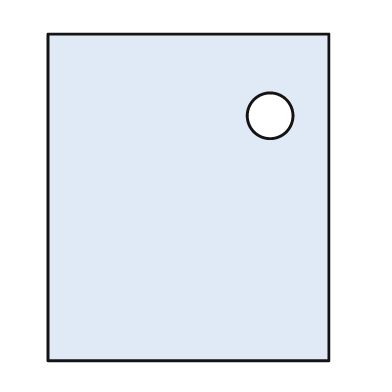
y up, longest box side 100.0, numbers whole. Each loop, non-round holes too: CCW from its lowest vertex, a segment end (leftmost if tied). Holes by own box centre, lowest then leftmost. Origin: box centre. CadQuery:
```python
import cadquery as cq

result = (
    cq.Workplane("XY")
    .moveTo(-43.0, -50.0)
    .lineTo(43.0, -50.0)
    .lineTo(43.0, 50.0)
    .lineTo(-43.0, 50.0)
    .close()
    .moveTo(25.0, 25.0)
    .circle(7.0)
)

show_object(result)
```